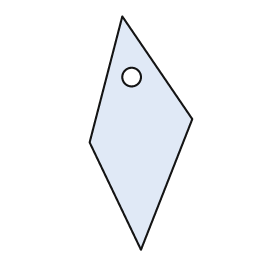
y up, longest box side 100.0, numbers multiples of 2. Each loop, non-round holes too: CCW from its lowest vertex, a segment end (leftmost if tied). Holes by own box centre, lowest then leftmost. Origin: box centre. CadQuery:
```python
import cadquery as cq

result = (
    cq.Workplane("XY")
    .moveTo(0.0, -50.0)
    .lineTo(22.0, 6.0)
    .lineTo(-8.0, 50.0)
    .lineTo(-22.0, -4.0)
    .close()
    .moveTo(-4.0, 24.0)
    .circle(4.0)
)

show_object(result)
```